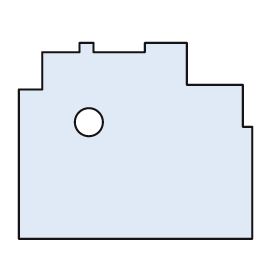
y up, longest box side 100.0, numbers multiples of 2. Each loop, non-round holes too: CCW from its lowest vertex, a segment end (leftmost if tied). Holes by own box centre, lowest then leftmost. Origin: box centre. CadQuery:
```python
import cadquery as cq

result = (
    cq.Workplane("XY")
    .moveTo(-50.0, -42.0)
    .lineTo(50.0, -42.0)
    .lineTo(50.0, 6.0)
    .lineTo(46.0, 6.0)
    .lineTo(46.0, 24.0)
    .lineTo(22.0, 24.0)
    .lineTo(22.0, 42.0)
    .lineTo(4.0, 42.0)
    .lineTo(4.0, 38.0)
    .lineTo(-18.0, 38.0)
    .lineTo(-18.0, 42.0)
    .lineTo(-24.0, 42.0)
    .lineTo(-24.0, 38.0)
    .lineTo(-40.0, 38.0)
    .lineTo(-40.0, 22.0)
    .lineTo(-50.0, 22.0)
    .close()
    .moveTo(-20.0, 8.0)
    .circle(6.0)
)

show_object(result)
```